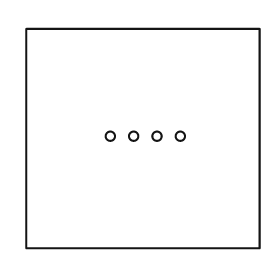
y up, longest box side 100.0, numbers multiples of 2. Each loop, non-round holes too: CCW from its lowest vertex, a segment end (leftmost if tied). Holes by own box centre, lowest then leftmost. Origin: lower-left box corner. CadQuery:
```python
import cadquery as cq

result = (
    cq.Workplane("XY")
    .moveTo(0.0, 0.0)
    .lineTo(100.0, 0.0)
    .lineTo(100.0, 94.0)
    .lineTo(0.0, 94.0)
    .close()
    .moveTo(36.0, 48.0)
    .circle(2.0)
    .moveTo(46.0, 48.0)
    .circle(2.0)
    .moveTo(56.0, 48.0)
    .circle(2.0)
    .moveTo(66.0, 48.0)
    .circle(2.0)
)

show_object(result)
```